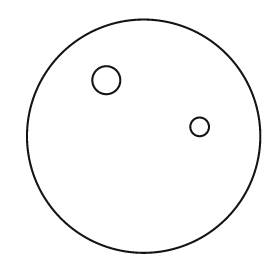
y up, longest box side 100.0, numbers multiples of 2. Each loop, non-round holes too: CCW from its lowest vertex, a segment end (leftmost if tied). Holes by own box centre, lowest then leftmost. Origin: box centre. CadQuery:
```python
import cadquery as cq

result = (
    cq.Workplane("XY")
    .moveTo(0.0, 0.0)
    .circle(50.0)
    .moveTo(24.0, 4.0)
    .circle(4.0)
    .moveTo(-16.0, 24.0)
    .circle(6.0)
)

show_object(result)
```